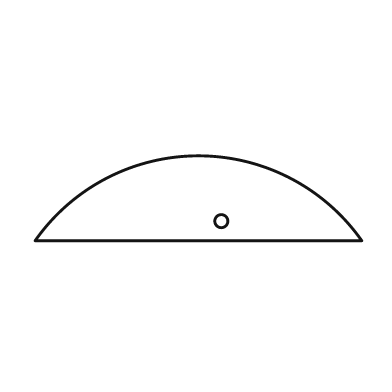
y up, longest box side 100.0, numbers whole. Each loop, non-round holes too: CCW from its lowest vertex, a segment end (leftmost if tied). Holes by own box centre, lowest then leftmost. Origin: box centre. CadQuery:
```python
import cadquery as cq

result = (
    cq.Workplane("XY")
    .moveTo(-50.0, -13.0)
    .lineTo(50.0, -13.0)
    .threePointArc((0.0, 13.0), (-50.0, -13.0))
    .close()
    .moveTo(7.0, -7.0)
    .circle(2.0)
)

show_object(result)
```